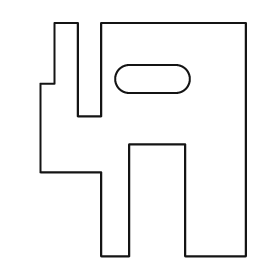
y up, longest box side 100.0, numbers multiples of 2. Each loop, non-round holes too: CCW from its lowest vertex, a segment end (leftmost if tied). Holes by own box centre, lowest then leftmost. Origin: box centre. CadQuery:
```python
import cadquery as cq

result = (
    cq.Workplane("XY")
    .moveTo(-18.0, -50.0)
    .lineTo(-6.0, -50.0)
    .lineTo(-6.0, -2.0)
    .lineTo(18.0, -2.0)
    .lineTo(18.0, -50.0)
    .lineTo(44.0, -50.0)
    .lineTo(44.0, 50.0)
    .lineTo(-18.0, 50.0)
    .lineTo(-18.0, 10.0)
    .lineTo(-28.0, 10.0)
    .lineTo(-28.0, 50.0)
    .lineTo(-38.0, 50.0)
    .lineTo(-38.0, 24.0)
    .lineTo(-44.0, 24.0)
    .lineTo(-44.0, -14.0)
    .lineTo(-18.0, -14.0)
    .close()
    .moveTo(-6.0, 20.0)
    .lineTo(14.0, 20.0)
    .threePointArc((20.0, 26.0), (14.0, 32.0))
    .lineTo(-6.0, 32.0)
    .threePointArc((-12.0, 26.0), (-6.0, 20.0))
    .close()
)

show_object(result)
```